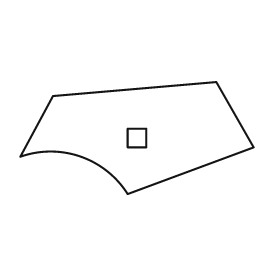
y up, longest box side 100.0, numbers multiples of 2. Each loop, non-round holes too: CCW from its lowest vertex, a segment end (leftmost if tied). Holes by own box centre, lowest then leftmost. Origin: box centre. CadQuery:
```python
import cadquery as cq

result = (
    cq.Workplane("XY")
    .moveTo(-4.0, -24.0)
    .lineTo(50.0, -4.0)
    .lineTo(34.0, 24.0)
    .lineTo(-36.0, 18.0)
    .lineTo(-50.0, -8.0)
    .threePointArc((-24.0, -8.0), (-4.0, -24.0))
    .close()
    .moveTo(-4.0, -4.0)
    .lineTo(4.0, -4.0)
    .lineTo(4.0, 4.0)
    .lineTo(-4.0, 4.0)
    .close()
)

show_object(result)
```